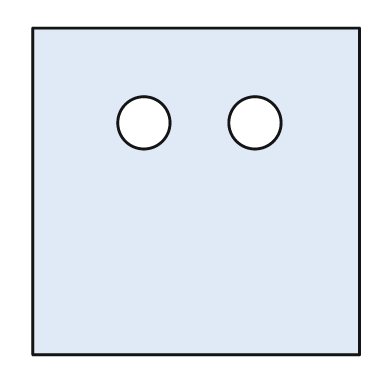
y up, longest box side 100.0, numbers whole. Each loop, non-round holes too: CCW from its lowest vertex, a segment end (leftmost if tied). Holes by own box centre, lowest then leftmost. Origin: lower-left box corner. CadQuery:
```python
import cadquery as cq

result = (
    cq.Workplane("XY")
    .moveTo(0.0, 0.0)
    .lineTo(100.0, 0.0)
    .lineTo(100.0, 100.0)
    .lineTo(0.0, 100.0)
    .close()
    .moveTo(34.0, 71.0)
    .circle(8.0)
    .moveTo(68.0, 71.0)
    .circle(8.0)
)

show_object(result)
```